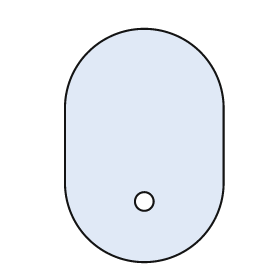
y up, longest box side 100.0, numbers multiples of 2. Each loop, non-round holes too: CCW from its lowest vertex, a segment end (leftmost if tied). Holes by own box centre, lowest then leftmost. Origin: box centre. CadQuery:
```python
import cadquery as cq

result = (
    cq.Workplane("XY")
    .moveTo(-34.0, -16.0)
    .threePointArc((0.0, -50.0), (34.0, -16.0))
    .lineTo(34.0, 16.0)
    .threePointArc((0.0, 50.0), (-34.0, 16.0))
    .close()
    .moveTo(0.0, -24.0)
    .circle(4.0)
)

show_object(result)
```